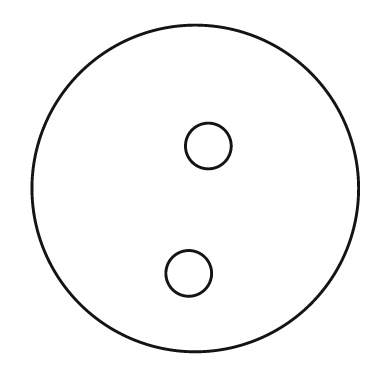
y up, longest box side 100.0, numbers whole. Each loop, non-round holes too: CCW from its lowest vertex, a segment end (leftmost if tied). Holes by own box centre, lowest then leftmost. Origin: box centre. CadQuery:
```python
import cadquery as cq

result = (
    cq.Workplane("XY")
    .moveTo(0.0, 0.0)
    .circle(50.0)
    .moveTo(-2.0, -26.0)
    .circle(7.0)
    .moveTo(4.0, 13.0)
    .circle(7.0)
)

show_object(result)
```